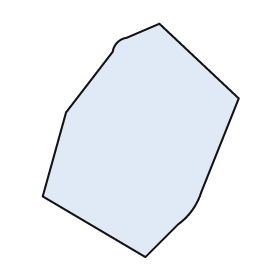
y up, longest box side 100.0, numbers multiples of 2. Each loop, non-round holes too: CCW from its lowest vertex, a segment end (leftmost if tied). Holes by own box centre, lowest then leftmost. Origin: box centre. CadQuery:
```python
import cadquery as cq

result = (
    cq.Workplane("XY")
    .moveTo(2.0, -50.0)
    .lineTo(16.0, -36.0)
    .threePointArc((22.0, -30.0), (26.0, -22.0))
    .lineTo(42.0, 18.0)
    .lineTo(8.0, 50.0)
    .lineTo(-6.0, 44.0)
    .threePointArc((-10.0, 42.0), (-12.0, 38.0))
    .lineTo(-32.0, 12.0)
    .lineTo(-42.0, -24.0)
    .close()
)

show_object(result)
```